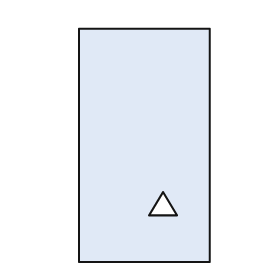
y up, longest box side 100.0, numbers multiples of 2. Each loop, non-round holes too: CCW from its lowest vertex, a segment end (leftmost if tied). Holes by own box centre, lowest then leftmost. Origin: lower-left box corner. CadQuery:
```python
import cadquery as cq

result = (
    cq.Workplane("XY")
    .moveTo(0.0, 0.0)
    .lineTo(56.0, 0.0)
    .lineTo(56.0, 100.0)
    .lineTo(0.0, 100.0)
    .close()
    .moveTo(30.0, 20.0)
    .lineTo(42.0, 20.0)
    .lineTo(36.0, 30.0)
    .close()
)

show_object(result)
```